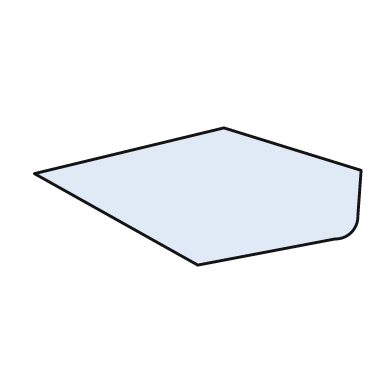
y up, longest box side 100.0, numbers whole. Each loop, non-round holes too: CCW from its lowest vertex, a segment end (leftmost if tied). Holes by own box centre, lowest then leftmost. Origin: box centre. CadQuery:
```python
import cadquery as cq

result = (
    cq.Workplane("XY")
    .moveTo(0.0, -21.0)
    .lineTo(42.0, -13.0)
    .threePointArc((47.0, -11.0), (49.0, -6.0))
    .lineTo(50.0, 8.0)
    .lineTo(8.0, 21.0)
    .lineTo(-50.0, 7.0)
    .close()
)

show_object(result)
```